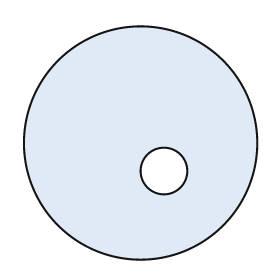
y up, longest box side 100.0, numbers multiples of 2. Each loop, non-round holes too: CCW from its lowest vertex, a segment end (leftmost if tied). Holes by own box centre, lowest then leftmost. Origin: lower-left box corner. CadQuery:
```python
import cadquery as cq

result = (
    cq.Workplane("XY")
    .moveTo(50.0, 50.0)
    .circle(50.0)
    .moveTo(60.0, 38.0)
    .circle(10.0)
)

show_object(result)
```